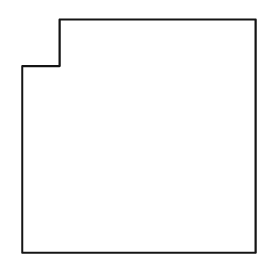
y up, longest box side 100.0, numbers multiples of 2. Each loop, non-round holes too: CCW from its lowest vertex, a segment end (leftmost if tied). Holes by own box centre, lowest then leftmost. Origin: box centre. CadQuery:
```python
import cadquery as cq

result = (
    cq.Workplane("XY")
    .moveTo(-50.0, -50.0)
    .lineTo(50.0, -50.0)
    .lineTo(50.0, 50.0)
    .lineTo(-34.0, 50.0)
    .lineTo(-34.0, 30.0)
    .lineTo(-50.0, 30.0)
    .close()
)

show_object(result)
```